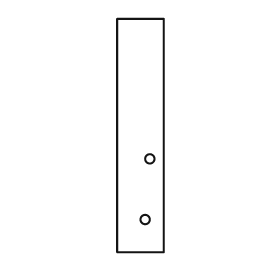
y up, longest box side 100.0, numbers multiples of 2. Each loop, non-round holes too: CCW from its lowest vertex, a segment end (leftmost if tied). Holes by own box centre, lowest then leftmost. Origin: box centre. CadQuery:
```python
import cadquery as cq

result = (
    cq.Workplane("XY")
    .moveTo(-10.0, -50.0)
    .lineTo(10.0, -50.0)
    .lineTo(10.0, 50.0)
    .lineTo(-10.0, 50.0)
    .close()
    .moveTo(2.0, -36.0)
    .circle(2.0)
    .moveTo(4.0, -10.0)
    .circle(2.0)
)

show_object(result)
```